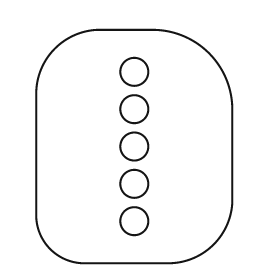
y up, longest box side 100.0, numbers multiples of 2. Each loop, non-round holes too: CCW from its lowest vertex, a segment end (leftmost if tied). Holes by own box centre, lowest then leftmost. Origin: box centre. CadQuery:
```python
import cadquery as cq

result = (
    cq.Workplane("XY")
    .moveTo(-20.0, -50.0)
    .lineTo(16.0, -50.0)
    .threePointArc((34.0, -42.0), (42.0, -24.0))
    .lineTo(42.0, 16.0)
    .threePointArc((32.0, 40.0), (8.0, 50.0))
    .lineTo(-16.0, 50.0)
    .threePointArc((-34.0, 42.0), (-42.0, 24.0))
    .lineTo(-42.0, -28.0)
    .threePointArc((-36.0, -44.0), (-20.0, -50.0))
    .close()
    .moveTo(0.0, -32.0)
    .circle(6.0)
    .moveTo(0.0, -16.0)
    .circle(6.0)
    .moveTo(0.0, 0.0)
    .circle(6.0)
    .moveTo(0.0, 16.0)
    .circle(6.0)
    .moveTo(0.0, 32.0)
    .circle(6.0)
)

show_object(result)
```